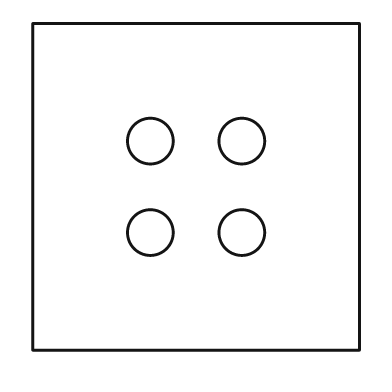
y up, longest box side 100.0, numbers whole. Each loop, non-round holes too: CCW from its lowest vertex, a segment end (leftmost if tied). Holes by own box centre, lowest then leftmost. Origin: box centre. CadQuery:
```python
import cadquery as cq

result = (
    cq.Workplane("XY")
    .moveTo(-50.0, -50.0)
    .lineTo(50.0, -50.0)
    .lineTo(50.0, 50.0)
    .lineTo(-50.0, 50.0)
    .close()
    .moveTo(-14.0, -14.0)
    .circle(7.0)
    .moveTo(14.0, -14.0)
    .circle(7.0)
    .moveTo(-14.0, 14.0)
    .circle(7.0)
    .moveTo(14.0, 14.0)
    .circle(7.0)
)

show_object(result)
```